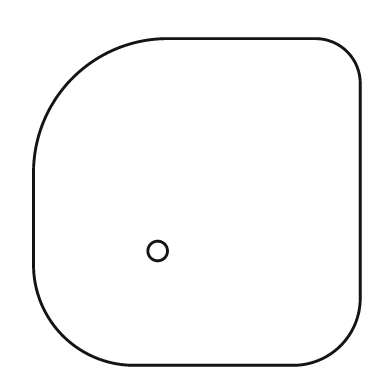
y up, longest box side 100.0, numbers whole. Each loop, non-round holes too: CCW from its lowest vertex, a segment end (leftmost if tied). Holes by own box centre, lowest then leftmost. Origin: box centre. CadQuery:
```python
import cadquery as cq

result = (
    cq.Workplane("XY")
    .moveTo(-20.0, -50.0)
    .lineTo(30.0, -50.0)
    .threePointArc((44.0, -44.0), (50.0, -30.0))
    .lineTo(50.0, 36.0)
    .threePointArc((46.0, 46.0), (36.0, 50.0))
    .lineTo(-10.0, 50.0)
    .threePointArc((-38.0, 38.0), (-50.0, 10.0))
    .lineTo(-50.0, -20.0)
    .threePointArc((-41.0, -41.0), (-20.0, -50.0))
    .close()
    .moveTo(-12.0, -15.0)
    .circle(3.0)
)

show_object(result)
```